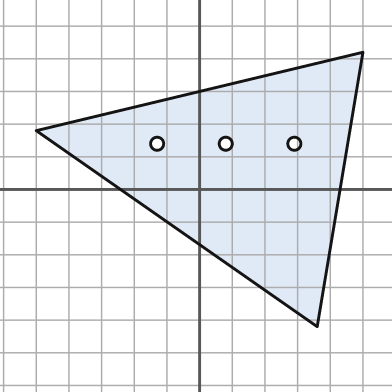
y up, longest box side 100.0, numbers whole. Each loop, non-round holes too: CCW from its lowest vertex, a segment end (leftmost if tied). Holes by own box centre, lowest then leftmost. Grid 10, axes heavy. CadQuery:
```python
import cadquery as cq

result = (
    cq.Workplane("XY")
    .moveTo(36.0, -42.0)
    .lineTo(50.0, 42.0)
    .lineTo(-50.0, 18.0)
    .close()
    .moveTo(-13.0, 14.0)
    .circle(2.0)
    .moveTo(8.0, 14.0)
    .circle(2.0)
    .moveTo(29.0, 14.0)
    .circle(2.0)
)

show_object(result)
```